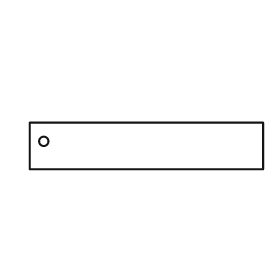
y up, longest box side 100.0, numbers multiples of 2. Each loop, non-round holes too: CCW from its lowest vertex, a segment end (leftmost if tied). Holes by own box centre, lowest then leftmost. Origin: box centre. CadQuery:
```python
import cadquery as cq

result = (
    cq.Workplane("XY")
    .moveTo(-50.0, -10.0)
    .lineTo(50.0, -10.0)
    .lineTo(50.0, 10.0)
    .lineTo(-50.0, 10.0)
    .close()
    .moveTo(-44.0, 2.0)
    .circle(2.0)
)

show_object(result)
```